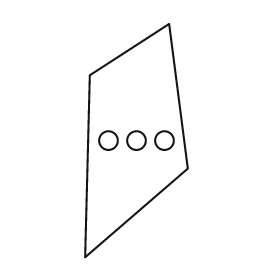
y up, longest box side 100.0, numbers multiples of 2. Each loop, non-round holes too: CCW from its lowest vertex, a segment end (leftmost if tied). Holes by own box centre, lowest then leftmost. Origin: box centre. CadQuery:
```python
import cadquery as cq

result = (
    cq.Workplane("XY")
    .moveTo(-22.0, -50.0)
    .lineTo(22.0, -12.0)
    .lineTo(14.0, 50.0)
    .lineTo(-20.0, 28.0)
    .close()
    .moveTo(-12.0, 0.0)
    .circle(4.0)
    .moveTo(0.0, 0.0)
    .circle(4.0)
    .moveTo(12.0, 0.0)
    .circle(4.0)
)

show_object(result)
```